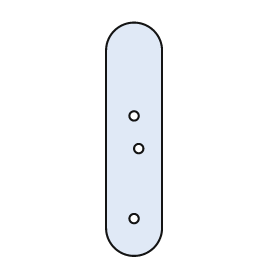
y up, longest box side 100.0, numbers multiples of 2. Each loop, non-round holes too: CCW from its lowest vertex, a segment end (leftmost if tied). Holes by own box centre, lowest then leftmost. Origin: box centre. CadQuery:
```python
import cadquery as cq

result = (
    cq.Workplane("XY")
    .moveTo(-12.0, -38.0)
    .threePointArc((0.0, -50.0), (12.0, -38.0))
    .lineTo(12.0, 38.0)
    .threePointArc((0.0, 50.0), (-12.0, 38.0))
    .close()
    .moveTo(0.0, -34.0)
    .circle(2.0)
    .moveTo(2.0, -4.0)
    .circle(2.0)
    .moveTo(0.0, 10.0)
    .circle(2.0)
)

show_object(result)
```